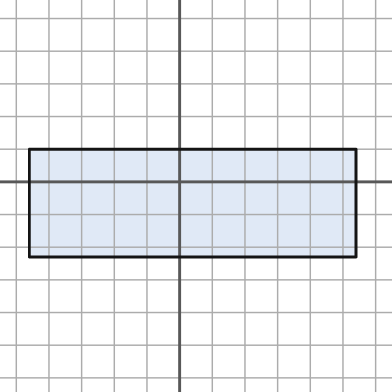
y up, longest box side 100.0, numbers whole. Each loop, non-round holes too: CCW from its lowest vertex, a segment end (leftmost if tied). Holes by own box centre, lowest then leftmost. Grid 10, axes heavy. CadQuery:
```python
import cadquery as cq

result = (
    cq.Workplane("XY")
    .moveTo(-46.0, -23.0)
    .lineTo(54.0, -23.0)
    .lineTo(54.0, 10.0)
    .lineTo(-46.0, 10.0)
    .close()
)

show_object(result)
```